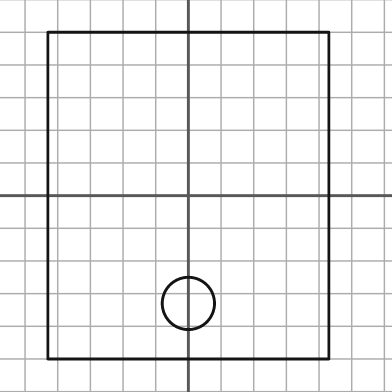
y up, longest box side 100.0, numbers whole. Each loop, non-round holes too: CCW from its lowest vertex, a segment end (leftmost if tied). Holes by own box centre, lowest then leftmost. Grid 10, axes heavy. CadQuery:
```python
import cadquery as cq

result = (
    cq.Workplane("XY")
    .moveTo(-43.0, -50.0)
    .lineTo(43.0, -50.0)
    .lineTo(43.0, 50.0)
    .lineTo(-43.0, 50.0)
    .close()
    .moveTo(0.0, -33.0)
    .circle(8.0)
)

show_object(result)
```